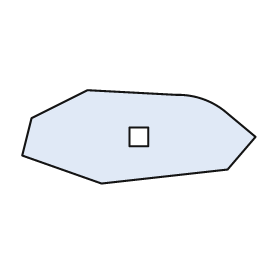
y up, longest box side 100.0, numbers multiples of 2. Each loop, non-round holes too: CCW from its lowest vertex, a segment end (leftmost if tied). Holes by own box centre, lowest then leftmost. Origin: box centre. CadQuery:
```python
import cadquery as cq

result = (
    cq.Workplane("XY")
    .moveTo(-16.0, -20.0)
    .lineTo(38.0, -14.0)
    .lineTo(50.0, 0.0)
    .lineTo(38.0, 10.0)
    .threePointArc((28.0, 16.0), (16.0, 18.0))
    .lineTo(-22.0, 20.0)
    .lineTo(-46.0, 8.0)
    .lineTo(-50.0, -8.0)
    .close()
    .moveTo(-4.0, -4.0)
    .lineTo(4.0, -4.0)
    .lineTo(4.0, 4.0)
    .lineTo(-4.0, 4.0)
    .close()
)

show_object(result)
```